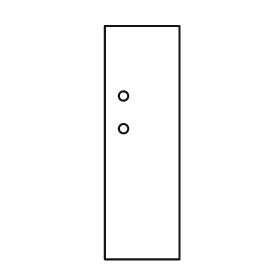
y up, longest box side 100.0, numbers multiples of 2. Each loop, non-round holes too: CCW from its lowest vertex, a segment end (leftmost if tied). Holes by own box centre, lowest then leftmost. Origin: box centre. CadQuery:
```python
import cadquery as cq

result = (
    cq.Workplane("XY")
    .moveTo(-16.0, -50.0)
    .lineTo(16.0, -50.0)
    .lineTo(16.0, 50.0)
    .lineTo(-16.0, 50.0)
    .close()
    .moveTo(-8.0, 6.0)
    .circle(2.0)
    .moveTo(-8.0, 20.0)
    .circle(2.0)
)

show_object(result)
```